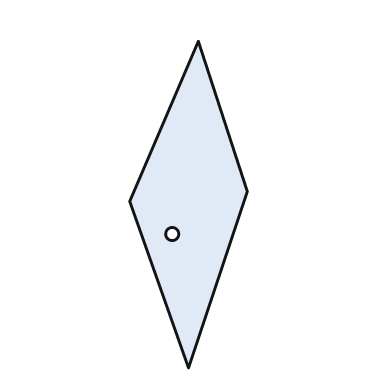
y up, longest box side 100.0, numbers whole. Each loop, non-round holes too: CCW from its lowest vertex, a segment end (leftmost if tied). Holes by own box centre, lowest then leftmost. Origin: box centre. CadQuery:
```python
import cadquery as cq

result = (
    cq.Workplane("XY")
    .moveTo(0.0, -50.0)
    .lineTo(18.0, 4.0)
    .lineTo(3.0, 50.0)
    .lineTo(-18.0, 1.0)
    .close()
    .moveTo(-5.0, -9.0)
    .circle(2.0)
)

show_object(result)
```